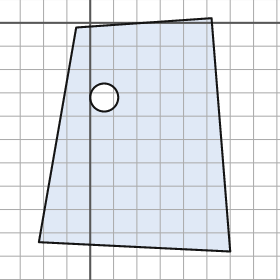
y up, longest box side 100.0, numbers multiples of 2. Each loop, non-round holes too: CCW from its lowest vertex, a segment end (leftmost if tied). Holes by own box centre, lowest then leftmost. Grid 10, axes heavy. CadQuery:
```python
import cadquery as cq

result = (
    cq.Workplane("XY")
    .moveTo(60.0, -98.0)
    .lineTo(52.0, 2.0)
    .lineTo(-6.0, -2.0)
    .lineTo(-22.0, -94.0)
    .close()
    .moveTo(6.0, -32.0)
    .circle(6.0)
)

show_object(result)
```